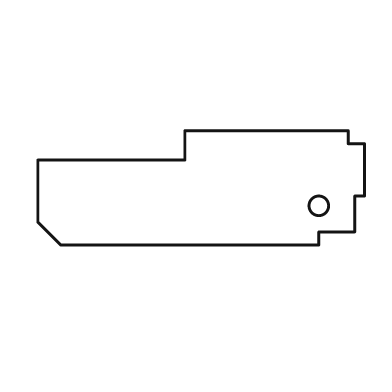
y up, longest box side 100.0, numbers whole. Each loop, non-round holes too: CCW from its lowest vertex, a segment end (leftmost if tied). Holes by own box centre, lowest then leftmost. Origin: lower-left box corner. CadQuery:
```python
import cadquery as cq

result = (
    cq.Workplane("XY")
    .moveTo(7.0, 0.0)
    .lineTo(86.0, 0.0)
    .lineTo(86.0, 4.0)
    .lineTo(97.0, 4.0)
    .lineTo(97.0, 15.0)
    .lineTo(100.0, 15.0)
    .lineTo(100.0, 31.0)
    .lineTo(95.0, 31.0)
    .lineTo(95.0, 35.0)
    .lineTo(45.0, 35.0)
    .lineTo(45.0, 26.0)
    .lineTo(0.0, 26.0)
    .lineTo(0.0, 7.0)
    .close()
    .moveTo(86.0, 12.0)
    .circle(3.0)
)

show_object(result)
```